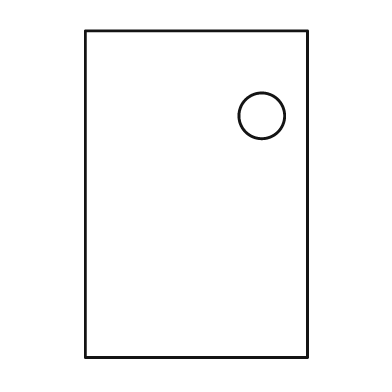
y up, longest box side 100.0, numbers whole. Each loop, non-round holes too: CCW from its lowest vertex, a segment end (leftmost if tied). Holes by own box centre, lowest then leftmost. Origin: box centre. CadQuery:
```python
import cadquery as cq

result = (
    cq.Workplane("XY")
    .moveTo(-34.0, -50.0)
    .lineTo(34.0, -50.0)
    .lineTo(34.0, 50.0)
    .lineTo(-34.0, 50.0)
    .close()
    .moveTo(20.0, 24.0)
    .circle(7.0)
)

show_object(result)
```